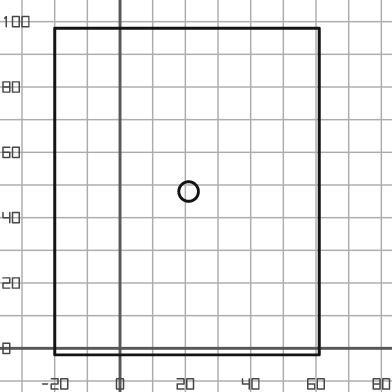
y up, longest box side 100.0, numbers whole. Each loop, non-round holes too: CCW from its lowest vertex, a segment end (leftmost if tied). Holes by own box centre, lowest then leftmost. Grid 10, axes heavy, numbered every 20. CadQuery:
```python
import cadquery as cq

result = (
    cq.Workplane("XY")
    .moveTo(-20.0, -2.0)
    .lineTo(61.0, -2.0)
    .lineTo(61.0, 98.0)
    .lineTo(-20.0, 98.0)
    .close()
    .moveTo(21.0, 48.0)
    .circle(3.0)
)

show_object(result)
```